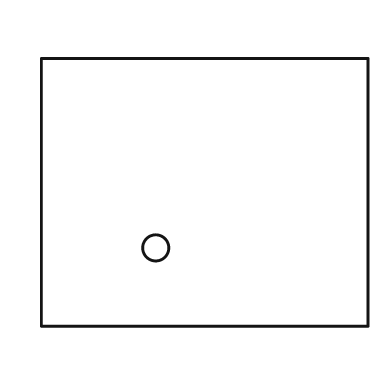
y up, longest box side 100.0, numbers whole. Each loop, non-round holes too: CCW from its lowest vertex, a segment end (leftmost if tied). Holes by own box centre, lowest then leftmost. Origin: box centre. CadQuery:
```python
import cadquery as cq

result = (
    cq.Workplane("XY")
    .moveTo(-50.0, -41.0)
    .lineTo(50.0, -41.0)
    .lineTo(50.0, 41.0)
    .lineTo(-50.0, 41.0)
    .close()
    .moveTo(-15.0, -17.0)
    .circle(4.0)
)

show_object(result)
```